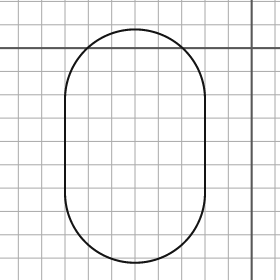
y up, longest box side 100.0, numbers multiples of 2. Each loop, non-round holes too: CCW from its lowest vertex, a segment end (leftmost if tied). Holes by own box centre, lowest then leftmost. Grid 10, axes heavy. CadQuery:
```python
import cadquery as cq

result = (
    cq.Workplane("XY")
    .moveTo(-80.0, -62.0)
    .threePointArc((-50.0, -92.0), (-20.0, -62.0))
    .lineTo(-20.0, -22.0)
    .threePointArc((-50.0, 8.0), (-80.0, -22.0))
    .close()
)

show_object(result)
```